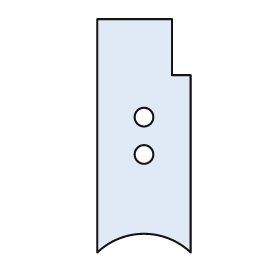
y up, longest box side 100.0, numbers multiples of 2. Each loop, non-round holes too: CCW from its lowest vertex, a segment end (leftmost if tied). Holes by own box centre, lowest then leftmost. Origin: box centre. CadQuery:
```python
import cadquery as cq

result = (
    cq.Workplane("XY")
    .moveTo(-20.0, -50.0)
    .threePointArc((0.0, -42.0), (20.0, -50.0))
    .lineTo(20.0, 26.0)
    .lineTo(12.0, 26.0)
    .lineTo(12.0, 50.0)
    .lineTo(-20.0, 50.0)
    .close()
    .moveTo(0.0, -8.0)
    .circle(4.0)
    .moveTo(0.0, 8.0)
    .circle(4.0)
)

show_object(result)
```